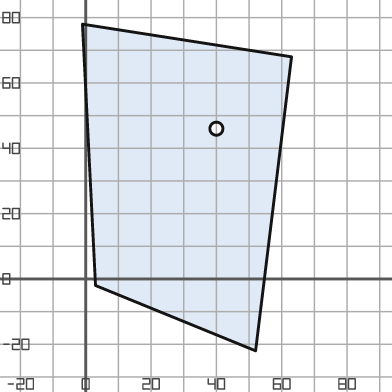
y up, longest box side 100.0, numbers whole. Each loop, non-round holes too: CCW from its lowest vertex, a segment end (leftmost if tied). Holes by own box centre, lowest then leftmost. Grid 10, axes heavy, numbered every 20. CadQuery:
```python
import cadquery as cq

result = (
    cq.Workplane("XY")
    .moveTo(52.0, -22.0)
    .lineTo(63.0, 68.0)
    .lineTo(-1.0, 78.0)
    .lineTo(3.0, -2.0)
    .close()
    .moveTo(40.0, 46.0)
    .circle(2.0)
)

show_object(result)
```